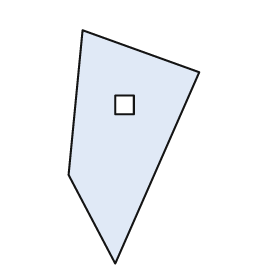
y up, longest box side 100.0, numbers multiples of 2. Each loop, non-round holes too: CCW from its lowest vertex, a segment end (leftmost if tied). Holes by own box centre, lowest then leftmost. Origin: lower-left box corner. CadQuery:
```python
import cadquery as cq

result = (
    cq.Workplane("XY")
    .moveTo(20.0, 0.0)
    .lineTo(56.0, 82.0)
    .lineTo(6.0, 100.0)
    .lineTo(0.0, 38.0)
    .close()
    .moveTo(20.0, 64.0)
    .lineTo(28.0, 64.0)
    .lineTo(28.0, 72.0)
    .lineTo(20.0, 72.0)
    .close()
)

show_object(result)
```